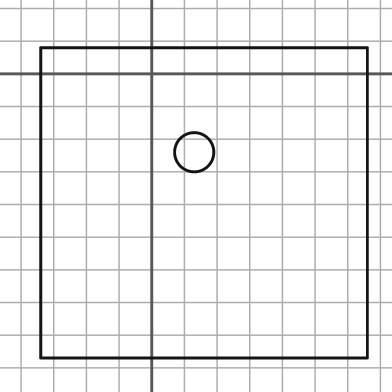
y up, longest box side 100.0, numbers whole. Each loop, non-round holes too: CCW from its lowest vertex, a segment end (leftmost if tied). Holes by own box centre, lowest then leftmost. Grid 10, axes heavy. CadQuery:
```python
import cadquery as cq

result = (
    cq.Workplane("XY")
    .moveTo(-34.0, -87.0)
    .lineTo(66.0, -87.0)
    .lineTo(66.0, 8.0)
    .lineTo(-34.0, 8.0)
    .close()
    .moveTo(13.0, -24.0)
    .circle(6.0)
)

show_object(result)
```